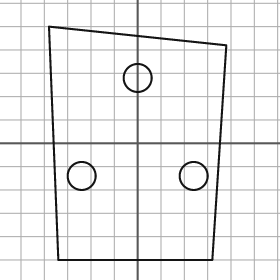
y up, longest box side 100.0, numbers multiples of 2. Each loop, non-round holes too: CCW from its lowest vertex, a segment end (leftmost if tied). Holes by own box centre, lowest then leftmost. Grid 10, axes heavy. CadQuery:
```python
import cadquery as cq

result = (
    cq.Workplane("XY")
    .moveTo(-34.0, -50.0)
    .lineTo(32.0, -50.0)
    .lineTo(38.0, 42.0)
    .lineTo(-38.0, 50.0)
    .close()
    .moveTo(-24.0, -14.0)
    .circle(6.0)
    .moveTo(24.0, -14.0)
    .circle(6.0)
    .moveTo(0.0, 28.0)
    .circle(6.0)
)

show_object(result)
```